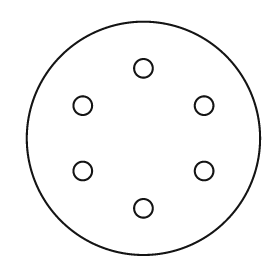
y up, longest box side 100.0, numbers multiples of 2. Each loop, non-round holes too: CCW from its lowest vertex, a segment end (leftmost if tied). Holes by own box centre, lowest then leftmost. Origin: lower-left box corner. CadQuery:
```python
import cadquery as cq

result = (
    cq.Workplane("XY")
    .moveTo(50.0, 50.0)
    .circle(50.0)
    .moveTo(50.0, 20.0)
    .circle(4.0)
    .moveTo(24.0, 36.0)
    .circle(4.0)
    .moveTo(76.0, 36.0)
    .circle(4.0)
    .moveTo(24.0, 64.0)
    .circle(4.0)
    .moveTo(76.0, 64.0)
    .circle(4.0)
    .moveTo(50.0, 80.0)
    .circle(4.0)
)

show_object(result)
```